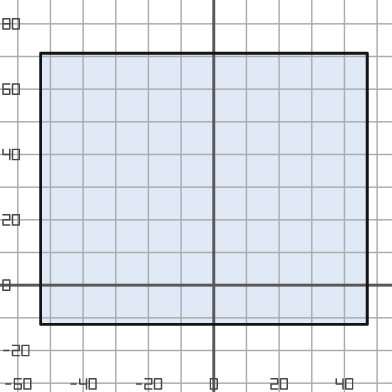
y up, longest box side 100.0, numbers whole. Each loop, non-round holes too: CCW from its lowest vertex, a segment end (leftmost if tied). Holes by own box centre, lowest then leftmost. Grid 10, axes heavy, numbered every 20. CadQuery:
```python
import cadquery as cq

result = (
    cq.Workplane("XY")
    .moveTo(-53.0, -12.0)
    .lineTo(47.0, -12.0)
    .lineTo(47.0, 71.0)
    .lineTo(-53.0, 71.0)
    .close()
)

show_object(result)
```